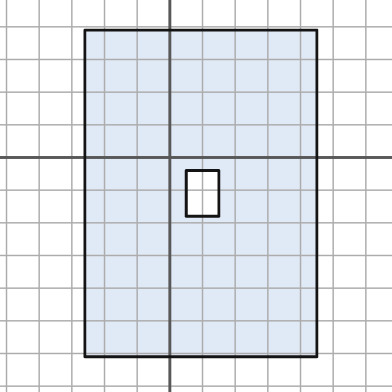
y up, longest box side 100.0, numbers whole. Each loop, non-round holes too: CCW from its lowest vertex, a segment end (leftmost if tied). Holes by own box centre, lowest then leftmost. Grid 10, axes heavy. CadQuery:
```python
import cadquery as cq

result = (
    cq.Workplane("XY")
    .moveTo(-26.0, -61.0)
    .lineTo(45.0, -61.0)
    .lineTo(45.0, 39.0)
    .lineTo(-26.0, 39.0)
    .close()
    .moveTo(5.0, -18.0)
    .lineTo(15.0, -18.0)
    .lineTo(15.0, -4.0)
    .lineTo(5.0, -4.0)
    .close()
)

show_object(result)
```